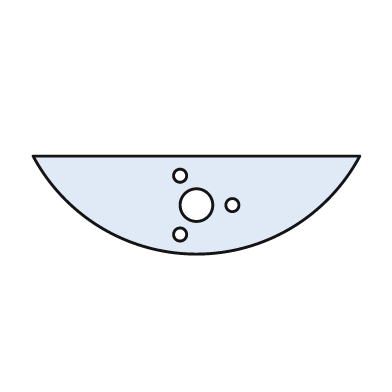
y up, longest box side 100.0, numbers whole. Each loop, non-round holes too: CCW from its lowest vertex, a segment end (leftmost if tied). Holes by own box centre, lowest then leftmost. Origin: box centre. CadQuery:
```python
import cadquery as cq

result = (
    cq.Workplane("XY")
    .moveTo(-50.0, 15.0)
    .threePointArc((0.0, -15.0), (50.0, 15.0))
    .close()
    .moveTo(-5.0, -9.0)
    .circle(2.0)
    .moveTo(0.0, 0.0)
    .circle(5.0)
    .moveTo(11.0, 0.0)
    .circle(2.0)
    .moveTo(-5.0, 9.0)
    .circle(2.0)
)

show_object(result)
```